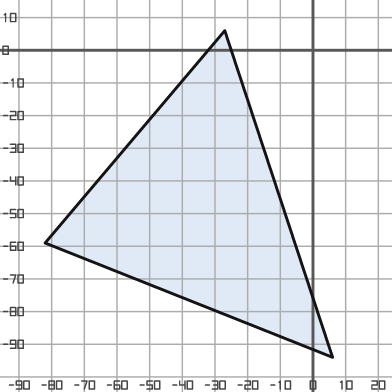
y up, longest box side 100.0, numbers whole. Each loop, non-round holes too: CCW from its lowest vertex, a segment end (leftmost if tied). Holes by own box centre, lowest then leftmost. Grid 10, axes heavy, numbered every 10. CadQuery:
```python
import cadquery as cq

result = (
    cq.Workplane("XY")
    .moveTo(6.0, -94.0)
    .lineTo(-27.0, 6.0)
    .lineTo(-82.0, -59.0)
    .close()
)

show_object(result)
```